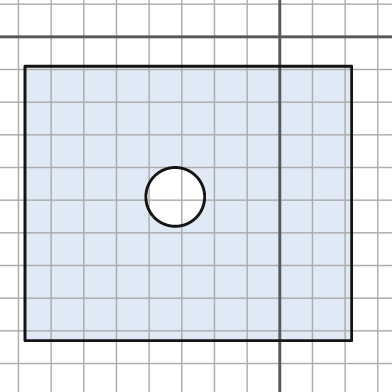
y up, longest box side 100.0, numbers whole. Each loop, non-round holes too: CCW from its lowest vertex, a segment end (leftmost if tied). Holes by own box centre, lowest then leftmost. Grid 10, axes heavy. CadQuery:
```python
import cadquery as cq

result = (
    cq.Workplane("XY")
    .moveTo(-78.0, -93.0)
    .lineTo(22.0, -93.0)
    .lineTo(22.0, -9.0)
    .lineTo(-78.0, -9.0)
    .close()
    .moveTo(-32.0, -49.0)
    .circle(9.0)
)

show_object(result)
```